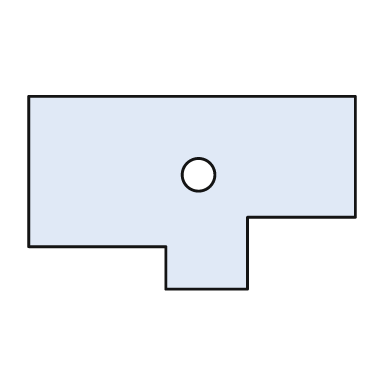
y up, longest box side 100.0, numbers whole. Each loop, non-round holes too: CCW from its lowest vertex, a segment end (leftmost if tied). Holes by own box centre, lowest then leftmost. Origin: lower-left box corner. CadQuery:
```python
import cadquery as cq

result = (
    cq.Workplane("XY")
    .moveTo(42.0, 0.0)
    .lineTo(67.0, 0.0)
    .lineTo(67.0, 22.0)
    .lineTo(100.0, 22.0)
    .lineTo(100.0, 59.0)
    .lineTo(0.0, 59.0)
    .lineTo(0.0, 13.0)
    .lineTo(42.0, 13.0)
    .close()
    .moveTo(52.0, 35.0)
    .circle(5.0)
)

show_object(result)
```